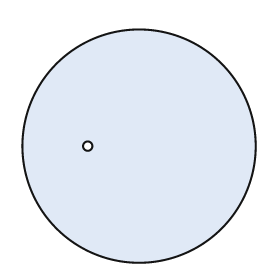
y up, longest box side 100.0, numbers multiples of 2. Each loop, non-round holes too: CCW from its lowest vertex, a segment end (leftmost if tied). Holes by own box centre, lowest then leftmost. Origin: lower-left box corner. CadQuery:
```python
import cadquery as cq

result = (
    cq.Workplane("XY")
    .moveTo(50.0, 50.0)
    .circle(50.0)
    .moveTo(28.0, 50.0)
    .circle(2.0)
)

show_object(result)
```